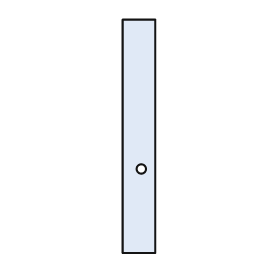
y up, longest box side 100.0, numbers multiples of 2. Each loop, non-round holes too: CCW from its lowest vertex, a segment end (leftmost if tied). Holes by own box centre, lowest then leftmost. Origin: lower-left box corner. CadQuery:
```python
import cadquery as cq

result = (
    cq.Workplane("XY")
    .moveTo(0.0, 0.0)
    .lineTo(14.0, 0.0)
    .lineTo(14.0, 100.0)
    .lineTo(0.0, 100.0)
    .close()
    .moveTo(8.0, 36.0)
    .circle(2.0)
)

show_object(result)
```